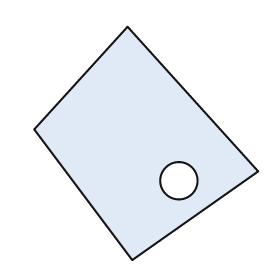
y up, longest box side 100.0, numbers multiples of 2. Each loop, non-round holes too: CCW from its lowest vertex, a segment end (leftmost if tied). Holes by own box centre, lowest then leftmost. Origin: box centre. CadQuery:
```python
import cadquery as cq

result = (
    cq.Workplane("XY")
    .moveTo(-6.0, -50.0)
    .lineTo(48.0, -12.0)
    .lineTo(-8.0, 50.0)
    .lineTo(-48.0, 6.0)
    .close()
    .moveTo(14.0, -16.0)
    .circle(8.0)
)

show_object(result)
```